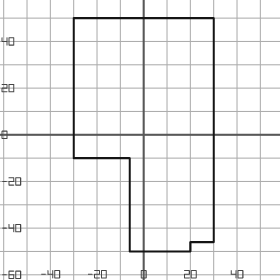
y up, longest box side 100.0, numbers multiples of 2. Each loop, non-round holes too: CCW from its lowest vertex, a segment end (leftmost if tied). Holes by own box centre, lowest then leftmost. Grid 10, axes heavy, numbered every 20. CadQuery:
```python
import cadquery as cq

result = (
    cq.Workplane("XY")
    .moveTo(-6.0, -50.0)
    .lineTo(20.0, -50.0)
    .lineTo(20.0, -46.0)
    .lineTo(30.0, -46.0)
    .lineTo(30.0, 50.0)
    .lineTo(-30.0, 50.0)
    .lineTo(-30.0, -10.0)
    .lineTo(-6.0, -10.0)
    .close()
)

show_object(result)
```